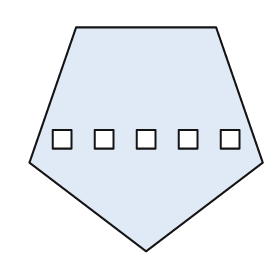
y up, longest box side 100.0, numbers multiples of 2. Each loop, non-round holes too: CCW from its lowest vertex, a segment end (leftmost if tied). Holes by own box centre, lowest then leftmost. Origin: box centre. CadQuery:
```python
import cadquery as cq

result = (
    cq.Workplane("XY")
    .moveTo(0.0, -48.0)
    .lineTo(50.0, -10.0)
    .lineTo(30.0, 48.0)
    .lineTo(-30.0, 48.0)
    .lineTo(-50.0, -10.0)
    .close()
    .moveTo(-40.0, -4.0)
    .lineTo(-32.0, -4.0)
    .lineTo(-32.0, 4.0)
    .lineTo(-40.0, 4.0)
    .close()
    .moveTo(-22.0, -4.0)
    .lineTo(-14.0, -4.0)
    .lineTo(-14.0, 4.0)
    .lineTo(-22.0, 4.0)
    .close()
    .moveTo(-4.0, -4.0)
    .lineTo(4.0, -4.0)
    .lineTo(4.0, 4.0)
    .lineTo(-4.0, 4.0)
    .close()
    .moveTo(14.0, -4.0)
    .lineTo(22.0, -4.0)
    .lineTo(22.0, 4.0)
    .lineTo(14.0, 4.0)
    .close()
    .moveTo(32.0, -4.0)
    .lineTo(40.0, -4.0)
    .lineTo(40.0, 4.0)
    .lineTo(32.0, 4.0)
    .close()
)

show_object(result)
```